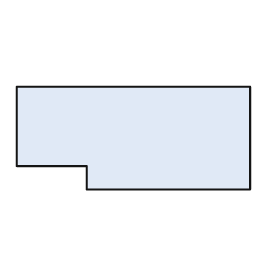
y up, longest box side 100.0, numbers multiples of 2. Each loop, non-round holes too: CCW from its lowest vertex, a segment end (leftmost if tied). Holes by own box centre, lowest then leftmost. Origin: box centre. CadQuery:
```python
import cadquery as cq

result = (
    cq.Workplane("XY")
    .moveTo(-20.0, -22.0)
    .lineTo(50.0, -22.0)
    .lineTo(50.0, 22.0)
    .lineTo(-50.0, 22.0)
    .lineTo(-50.0, -12.0)
    .lineTo(-20.0, -12.0)
    .close()
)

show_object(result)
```